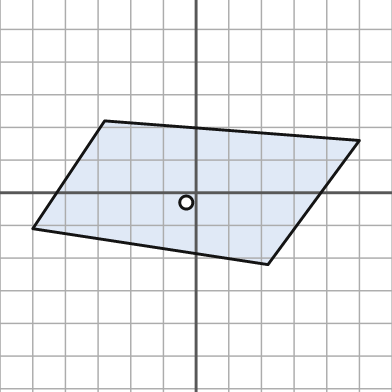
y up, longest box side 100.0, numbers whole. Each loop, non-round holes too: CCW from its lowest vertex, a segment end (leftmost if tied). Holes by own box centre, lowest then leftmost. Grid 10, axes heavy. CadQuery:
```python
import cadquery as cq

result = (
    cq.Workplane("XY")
    .moveTo(22.0, -22.0)
    .lineTo(50.0, 16.0)
    .lineTo(-28.0, 22.0)
    .lineTo(-50.0, -11.0)
    .close()
    .moveTo(-3.0, -3.0)
    .circle(2.0)
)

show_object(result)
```